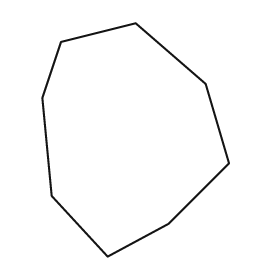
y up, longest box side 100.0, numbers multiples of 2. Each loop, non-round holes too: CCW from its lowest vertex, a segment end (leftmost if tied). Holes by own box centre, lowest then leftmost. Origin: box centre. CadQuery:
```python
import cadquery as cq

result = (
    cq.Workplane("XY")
    .moveTo(-12.0, -50.0)
    .lineTo(14.0, -36.0)
    .lineTo(40.0, -10.0)
    .lineTo(30.0, 24.0)
    .lineTo(0.0, 50.0)
    .lineTo(-32.0, 42.0)
    .lineTo(-40.0, 18.0)
    .lineTo(-36.0, -24.0)
    .close()
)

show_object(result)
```